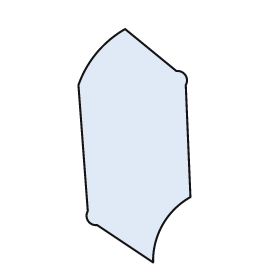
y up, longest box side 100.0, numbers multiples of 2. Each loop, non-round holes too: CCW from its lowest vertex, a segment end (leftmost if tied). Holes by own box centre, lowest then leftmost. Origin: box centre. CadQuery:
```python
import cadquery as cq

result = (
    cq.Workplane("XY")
    .moveTo(8.0, -50.0)
    .threePointArc((12.0, -34.0), (24.0, -22.0))
    .lineTo(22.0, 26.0)
    .threePointArc((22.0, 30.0), (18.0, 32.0))
    .lineTo(-4.0, 50.0)
    .threePointArc((-16.0, 40.0), (-24.0, 26.0))
    .lineTo(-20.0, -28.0)
    .threePointArc((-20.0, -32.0), (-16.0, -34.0))
    .close()
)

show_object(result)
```